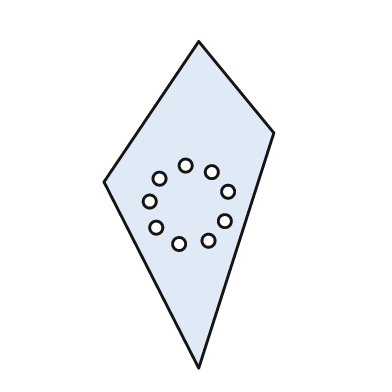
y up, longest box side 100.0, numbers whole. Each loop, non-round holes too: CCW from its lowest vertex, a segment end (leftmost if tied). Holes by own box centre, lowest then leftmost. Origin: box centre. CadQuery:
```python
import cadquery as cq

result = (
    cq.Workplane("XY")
    .moveTo(3.0, -50.0)
    .lineTo(26.0, 22.0)
    .lineTo(3.0, 50.0)
    .lineTo(-26.0, 7.0)
    .close()
    .moveTo(-3.0, -12.0)
    .circle(2.0)
    .moveTo(6.0, -11.0)
    .circle(2.0)
    .moveTo(-10.0, -7.0)
    .circle(2.0)
    .moveTo(11.0, -5.0)
    .circle(2.0)
    .moveTo(-12.0, 1.0)
    .circle(2.0)
    .moveTo(12.0, 4.0)
    .circle(2.0)
    .moveTo(-9.0, 8.0)
    .circle(2.0)
    .moveTo(7.0, 10.0)
    .circle(2.0)
    .moveTo(-1.0, 12.0)
    .circle(2.0)
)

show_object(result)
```